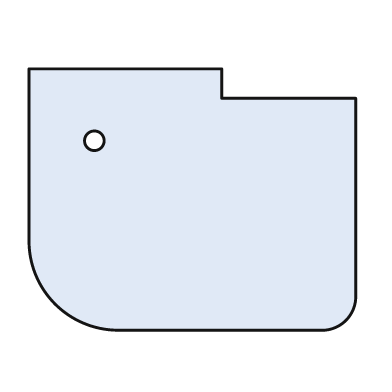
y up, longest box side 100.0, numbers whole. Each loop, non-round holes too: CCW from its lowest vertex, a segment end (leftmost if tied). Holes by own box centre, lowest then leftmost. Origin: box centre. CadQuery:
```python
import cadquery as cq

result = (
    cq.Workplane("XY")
    .moveTo(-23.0, -40.0)
    .lineTo(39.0, -40.0)
    .threePointArc((47.0, -37.0), (50.0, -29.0))
    .lineTo(50.0, 31.0)
    .lineTo(9.0, 31.0)
    .lineTo(9.0, 40.0)
    .lineTo(-50.0, 40.0)
    .lineTo(-50.0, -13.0)
    .threePointArc((-42.0, -32.0), (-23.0, -40.0))
    .close()
    .moveTo(-30.0, 18.0)
    .circle(3.0)
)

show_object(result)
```